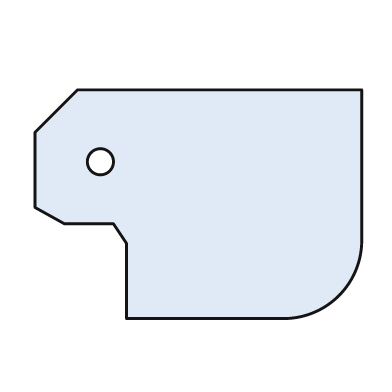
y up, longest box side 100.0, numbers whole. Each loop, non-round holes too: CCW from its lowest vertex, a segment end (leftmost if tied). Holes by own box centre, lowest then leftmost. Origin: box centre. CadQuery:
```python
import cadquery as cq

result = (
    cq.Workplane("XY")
    .moveTo(-22.0, -35.0)
    .lineTo(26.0, -35.0)
    .threePointArc((43.0, -28.0), (50.0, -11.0))
    .lineTo(50.0, 35.0)
    .lineTo(-37.0, 35.0)
    .lineTo(-50.0, 22.0)
    .lineTo(-50.0, -1.0)
    .lineTo(-41.0, -6.0)
    .lineTo(-26.0, -6.0)
    .lineTo(-22.0, -12.0)
    .close()
    .moveTo(-30.0, 13.0)
    .circle(4.0)
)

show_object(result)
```